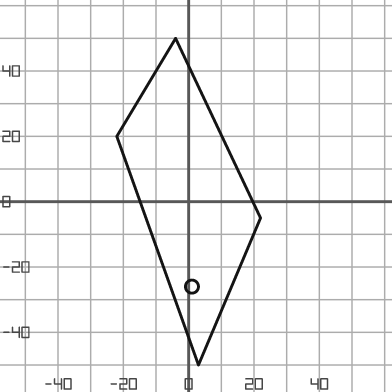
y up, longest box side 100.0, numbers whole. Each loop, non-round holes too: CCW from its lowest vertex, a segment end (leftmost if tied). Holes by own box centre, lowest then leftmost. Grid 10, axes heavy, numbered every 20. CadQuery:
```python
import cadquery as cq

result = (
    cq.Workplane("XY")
    .moveTo(3.0, -50.0)
    .lineTo(22.0, -5.0)
    .lineTo(-4.0, 50.0)
    .lineTo(-22.0, 20.0)
    .close()
    .moveTo(1.0, -26.0)
    .circle(2.0)
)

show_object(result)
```